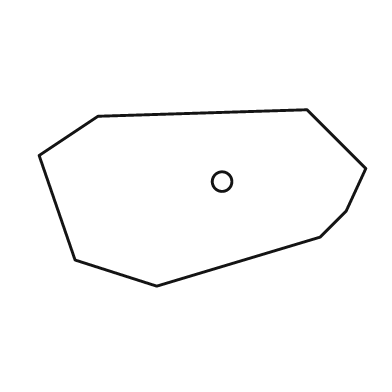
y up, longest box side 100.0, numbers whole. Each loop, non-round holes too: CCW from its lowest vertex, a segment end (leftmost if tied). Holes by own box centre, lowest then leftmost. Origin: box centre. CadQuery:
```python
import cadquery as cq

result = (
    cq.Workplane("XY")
    .moveTo(-14.0, -27.0)
    .lineTo(36.0, -12.0)
    .lineTo(44.0, -4.0)
    .lineTo(50.0, 9.0)
    .lineTo(32.0, 27.0)
    .lineTo(-32.0, 25.0)
    .lineTo(-50.0, 13.0)
    .lineTo(-39.0, -19.0)
    .close()
    .moveTo(6.0, 5.0)
    .circle(3.0)
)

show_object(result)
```